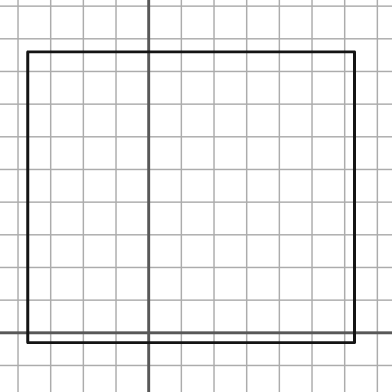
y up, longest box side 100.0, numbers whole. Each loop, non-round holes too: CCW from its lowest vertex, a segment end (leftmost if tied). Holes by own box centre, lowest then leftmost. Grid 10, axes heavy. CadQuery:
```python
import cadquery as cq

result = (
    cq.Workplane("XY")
    .moveTo(-37.0, -3.0)
    .lineTo(63.0, -3.0)
    .lineTo(63.0, 86.0)
    .lineTo(-37.0, 86.0)
    .close()
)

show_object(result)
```